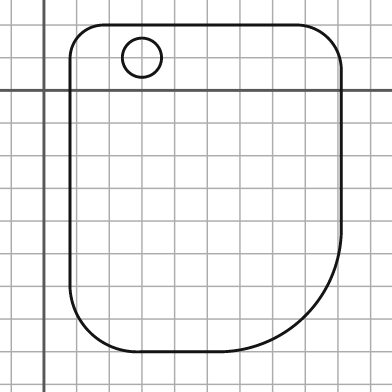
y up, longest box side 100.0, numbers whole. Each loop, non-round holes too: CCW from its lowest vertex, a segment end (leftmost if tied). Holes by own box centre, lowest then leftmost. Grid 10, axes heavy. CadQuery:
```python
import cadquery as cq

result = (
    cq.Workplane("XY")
    .moveTo(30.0, -80.0)
    .lineTo(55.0, -80.0)
    .threePointArc((80.0, -69.0), (91.0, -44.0))
    .lineTo(91.0, 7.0)
    .threePointArc((87.0, 16.0), (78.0, 20.0))
    .lineTo(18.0, 20.0)
    .threePointArc((11.0, 17.0), (8.0, 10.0))
    .lineTo(8.0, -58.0)
    .threePointArc((14.0, -74.0), (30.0, -80.0))
    .close()
    .moveTo(30.0, 10.0)
    .circle(6.0)
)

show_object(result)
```